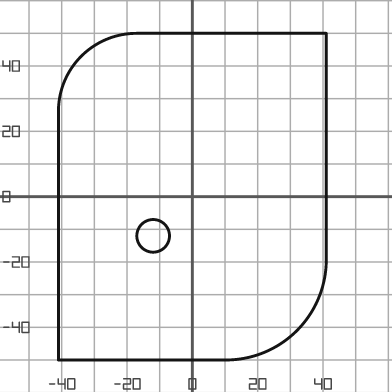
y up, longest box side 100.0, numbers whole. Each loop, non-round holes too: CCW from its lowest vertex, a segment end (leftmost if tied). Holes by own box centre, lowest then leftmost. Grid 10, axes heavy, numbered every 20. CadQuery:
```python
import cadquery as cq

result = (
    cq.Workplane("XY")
    .moveTo(-41.0, -50.0)
    .lineTo(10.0, -50.0)
    .threePointArc((32.0, -41.0), (41.0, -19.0))
    .lineTo(41.0, 50.0)
    .lineTo(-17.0, 50.0)
    .threePointArc((-34.0, 43.0), (-41.0, 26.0))
    .close()
    .moveTo(-12.0, -12.0)
    .circle(5.0)
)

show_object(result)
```